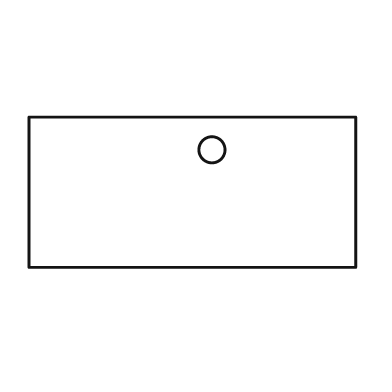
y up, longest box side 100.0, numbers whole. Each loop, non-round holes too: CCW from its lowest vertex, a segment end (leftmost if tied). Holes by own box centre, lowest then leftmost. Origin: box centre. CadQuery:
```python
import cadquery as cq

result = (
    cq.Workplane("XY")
    .moveTo(-50.0, -23.0)
    .lineTo(50.0, -23.0)
    .lineTo(50.0, 23.0)
    .lineTo(-50.0, 23.0)
    .close()
    .moveTo(6.0, 13.0)
    .circle(4.0)
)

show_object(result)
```